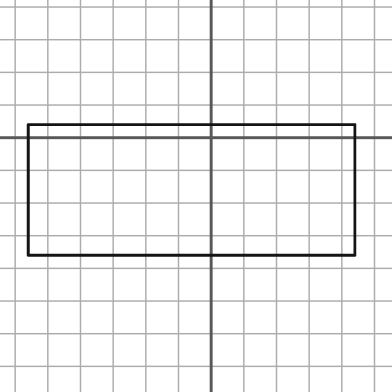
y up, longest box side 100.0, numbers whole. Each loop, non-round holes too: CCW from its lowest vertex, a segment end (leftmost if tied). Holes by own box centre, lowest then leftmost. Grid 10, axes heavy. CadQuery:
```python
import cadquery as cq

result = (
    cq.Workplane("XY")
    .moveTo(-56.0, -36.0)
    .lineTo(44.0, -36.0)
    .lineTo(44.0, 4.0)
    .lineTo(-56.0, 4.0)
    .close()
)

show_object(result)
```